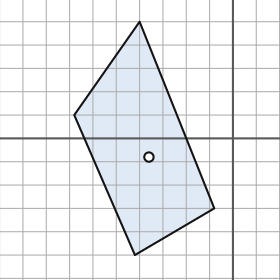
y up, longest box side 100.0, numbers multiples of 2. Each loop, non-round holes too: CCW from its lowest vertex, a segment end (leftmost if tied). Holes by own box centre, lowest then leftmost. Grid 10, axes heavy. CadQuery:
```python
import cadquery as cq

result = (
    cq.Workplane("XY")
    .moveTo(-42.0, -50.0)
    .lineTo(-8.0, -30.0)
    .lineTo(-40.0, 50.0)
    .lineTo(-68.0, 10.0)
    .close()
    .moveTo(-36.0, -8.0)
    .circle(2.0)
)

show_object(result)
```